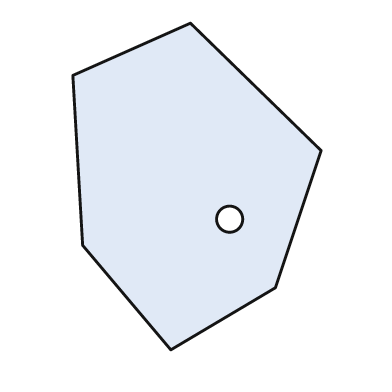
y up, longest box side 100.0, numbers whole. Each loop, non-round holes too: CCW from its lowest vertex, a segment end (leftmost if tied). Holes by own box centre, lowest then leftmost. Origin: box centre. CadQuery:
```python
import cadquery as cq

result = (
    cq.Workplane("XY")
    .moveTo(-8.0, -50.0)
    .lineTo(24.0, -31.0)
    .lineTo(38.0, 11.0)
    .lineTo(-2.0, 50.0)
    .lineTo(-38.0, 34.0)
    .lineTo(-35.0, -18.0)
    .close()
    .moveTo(10.0, -10.0)
    .circle(4.0)
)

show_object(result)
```